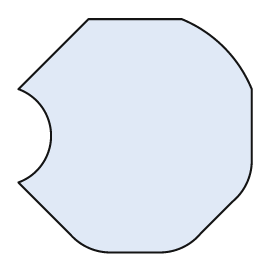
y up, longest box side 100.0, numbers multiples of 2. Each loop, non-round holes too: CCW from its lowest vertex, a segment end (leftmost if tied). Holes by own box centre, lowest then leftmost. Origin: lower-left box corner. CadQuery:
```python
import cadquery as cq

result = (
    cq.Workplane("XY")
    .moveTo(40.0, 0.0)
    .lineTo(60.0, 0.0)
    .threePointArc((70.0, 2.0), (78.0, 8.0))
    .lineTo(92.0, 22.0)
    .threePointArc((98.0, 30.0), (100.0, 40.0))
    .lineTo(100.0, 70.0)
    .threePointArc((88.0, 88.0), (70.0, 100.0))
    .lineTo(30.0, 100.0)
    .lineTo(0.0, 70.0)
    .threePointArc((14.0, 50.0), (0.0, 30.0))
    .lineTo(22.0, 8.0)
    .threePointArc((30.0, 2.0), (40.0, 0.0))
    .close()
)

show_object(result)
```